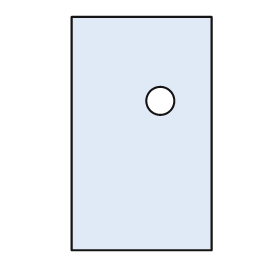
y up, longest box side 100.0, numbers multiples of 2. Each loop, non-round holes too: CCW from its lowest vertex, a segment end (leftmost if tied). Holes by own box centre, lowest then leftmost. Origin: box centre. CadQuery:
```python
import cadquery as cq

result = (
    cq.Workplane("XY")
    .moveTo(-30.0, -50.0)
    .lineTo(30.0, -50.0)
    .lineTo(30.0, 50.0)
    .lineTo(-30.0, 50.0)
    .close()
    .moveTo(8.0, 14.0)
    .circle(6.0)
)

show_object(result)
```